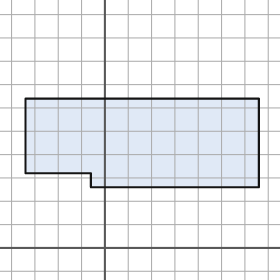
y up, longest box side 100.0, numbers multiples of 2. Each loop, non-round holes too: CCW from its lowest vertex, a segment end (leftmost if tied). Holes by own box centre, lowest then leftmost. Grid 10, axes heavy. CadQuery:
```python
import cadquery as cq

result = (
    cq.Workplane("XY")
    .moveTo(-6.0, 26.0)
    .lineTo(66.0, 26.0)
    .lineTo(66.0, 64.0)
    .lineTo(-34.0, 64.0)
    .lineTo(-34.0, 32.0)
    .lineTo(-6.0, 32.0)
    .close()
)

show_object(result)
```